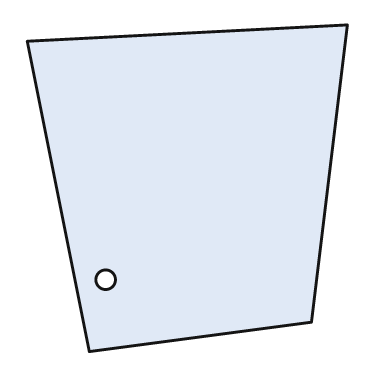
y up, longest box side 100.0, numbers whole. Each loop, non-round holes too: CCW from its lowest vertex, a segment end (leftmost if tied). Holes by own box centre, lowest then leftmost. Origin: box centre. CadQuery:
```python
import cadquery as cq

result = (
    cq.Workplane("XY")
    .moveTo(-30.0, -50.0)
    .lineTo(38.0, -41.0)
    .lineTo(49.0, 50.0)
    .lineTo(-49.0, 45.0)
    .close()
    .moveTo(-25.0, -28.0)
    .circle(3.0)
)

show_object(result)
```